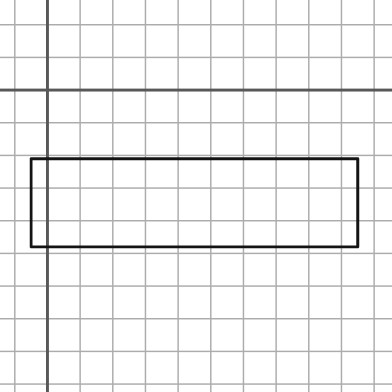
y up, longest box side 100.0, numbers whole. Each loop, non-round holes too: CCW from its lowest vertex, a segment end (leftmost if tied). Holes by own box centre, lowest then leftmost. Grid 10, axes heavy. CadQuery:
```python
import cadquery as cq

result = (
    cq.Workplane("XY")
    .moveTo(-5.0, -48.0)
    .lineTo(95.0, -48.0)
    .lineTo(95.0, -21.0)
    .lineTo(-5.0, -21.0)
    .close()
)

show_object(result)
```